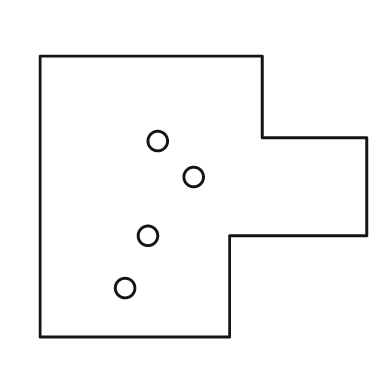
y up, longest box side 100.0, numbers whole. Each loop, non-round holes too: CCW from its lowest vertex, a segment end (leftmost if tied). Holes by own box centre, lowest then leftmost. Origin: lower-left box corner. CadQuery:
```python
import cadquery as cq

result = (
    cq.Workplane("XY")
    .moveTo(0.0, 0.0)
    .lineTo(58.0, 0.0)
    .lineTo(58.0, 31.0)
    .lineTo(100.0, 31.0)
    .lineTo(100.0, 61.0)
    .lineTo(68.0, 61.0)
    .lineTo(68.0, 86.0)
    .lineTo(0.0, 86.0)
    .close()
    .moveTo(26.0, 15.0)
    .circle(3.0)
    .moveTo(33.0, 31.0)
    .circle(3.0)
    .moveTo(47.0, 49.0)
    .circle(3.0)
    .moveTo(36.0, 60.0)
    .circle(3.0)
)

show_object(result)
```